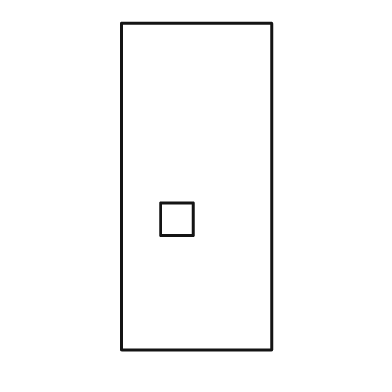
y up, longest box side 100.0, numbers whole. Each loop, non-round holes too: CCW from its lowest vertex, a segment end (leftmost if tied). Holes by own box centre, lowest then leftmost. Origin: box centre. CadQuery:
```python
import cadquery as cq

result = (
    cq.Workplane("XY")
    .moveTo(-23.0, -50.0)
    .lineTo(23.0, -50.0)
    .lineTo(23.0, 50.0)
    .lineTo(-23.0, 50.0)
    .close()
    .moveTo(-11.0, -15.0)
    .lineTo(-1.0, -15.0)
    .lineTo(-1.0, -5.0)
    .lineTo(-11.0, -5.0)
    .close()
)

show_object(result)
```